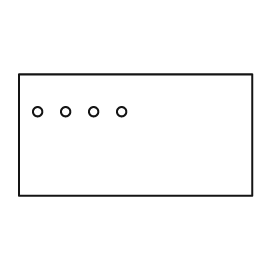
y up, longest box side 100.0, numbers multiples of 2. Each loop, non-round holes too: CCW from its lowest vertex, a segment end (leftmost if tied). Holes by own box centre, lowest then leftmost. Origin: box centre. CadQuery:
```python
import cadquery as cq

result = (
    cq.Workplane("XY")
    .moveTo(-50.0, -26.0)
    .lineTo(50.0, -26.0)
    .lineTo(50.0, 26.0)
    .lineTo(-50.0, 26.0)
    .close()
    .moveTo(-42.0, 10.0)
    .circle(2.0)
    .moveTo(-30.0, 10.0)
    .circle(2.0)
    .moveTo(-18.0, 10.0)
    .circle(2.0)
    .moveTo(-6.0, 10.0)
    .circle(2.0)
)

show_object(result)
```